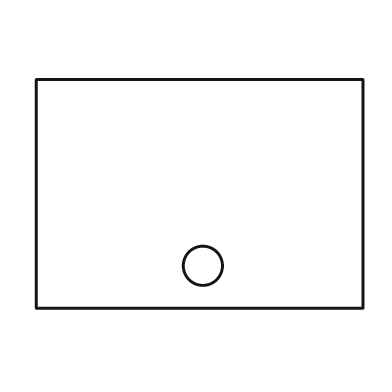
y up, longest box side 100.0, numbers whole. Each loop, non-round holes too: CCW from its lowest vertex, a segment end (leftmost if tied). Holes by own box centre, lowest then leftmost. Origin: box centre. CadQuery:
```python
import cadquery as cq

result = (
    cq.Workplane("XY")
    .moveTo(-50.0, -35.0)
    .lineTo(50.0, -35.0)
    .lineTo(50.0, 35.0)
    .lineTo(-50.0, 35.0)
    .close()
    .moveTo(1.0, -22.0)
    .circle(6.0)
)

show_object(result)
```